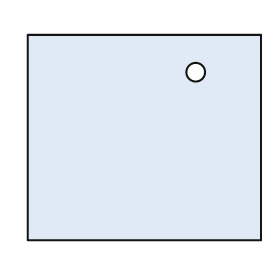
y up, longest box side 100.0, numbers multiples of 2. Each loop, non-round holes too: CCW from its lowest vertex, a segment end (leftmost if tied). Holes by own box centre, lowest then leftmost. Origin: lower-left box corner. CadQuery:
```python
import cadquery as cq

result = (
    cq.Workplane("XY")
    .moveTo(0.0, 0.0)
    .lineTo(100.0, 0.0)
    .lineTo(100.0, 88.0)
    .lineTo(0.0, 88.0)
    .close()
    .moveTo(72.0, 72.0)
    .circle(4.0)
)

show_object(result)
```